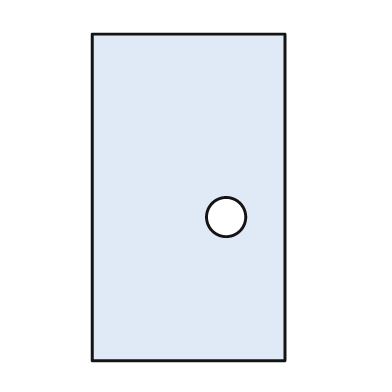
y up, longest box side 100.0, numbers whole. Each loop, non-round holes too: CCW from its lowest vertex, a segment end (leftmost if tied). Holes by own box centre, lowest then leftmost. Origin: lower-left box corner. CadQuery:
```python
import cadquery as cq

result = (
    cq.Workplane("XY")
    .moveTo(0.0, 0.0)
    .lineTo(59.0, 0.0)
    .lineTo(59.0, 100.0)
    .lineTo(0.0, 100.0)
    .close()
    .moveTo(41.0, 44.0)
    .circle(6.0)
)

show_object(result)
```